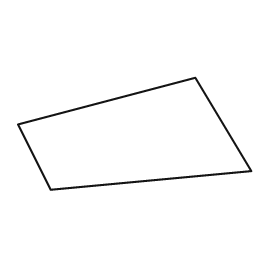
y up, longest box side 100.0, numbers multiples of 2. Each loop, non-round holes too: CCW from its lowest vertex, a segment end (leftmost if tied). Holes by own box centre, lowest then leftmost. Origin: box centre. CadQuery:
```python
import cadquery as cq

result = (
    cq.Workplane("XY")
    .moveTo(-36.0, -24.0)
    .lineTo(50.0, -16.0)
    .lineTo(26.0, 24.0)
    .lineTo(-50.0, 4.0)
    .close()
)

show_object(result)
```